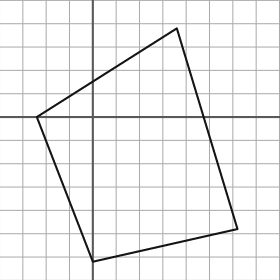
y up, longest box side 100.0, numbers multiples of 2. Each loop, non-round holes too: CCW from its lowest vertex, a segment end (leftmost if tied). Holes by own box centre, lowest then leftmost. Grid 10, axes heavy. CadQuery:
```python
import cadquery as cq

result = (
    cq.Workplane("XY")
    .moveTo(0.0, -62.0)
    .lineTo(62.0, -48.0)
    .lineTo(36.0, 38.0)
    .lineTo(-24.0, 0.0)
    .close()
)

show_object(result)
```